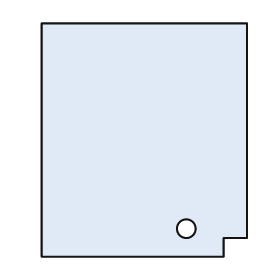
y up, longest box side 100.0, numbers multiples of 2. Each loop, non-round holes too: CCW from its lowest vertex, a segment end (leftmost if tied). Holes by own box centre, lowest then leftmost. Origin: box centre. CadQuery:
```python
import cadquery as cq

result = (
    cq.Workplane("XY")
    .moveTo(-44.0, -50.0)
    .lineTo(34.0, -50.0)
    .lineTo(34.0, -42.0)
    .lineTo(44.0, -42.0)
    .lineTo(44.0, 50.0)
    .lineTo(-44.0, 50.0)
    .close()
    .moveTo(18.0, -38.0)
    .circle(4.0)
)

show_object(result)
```